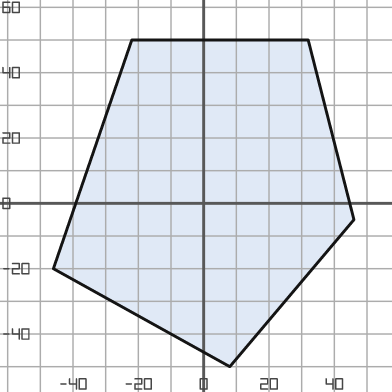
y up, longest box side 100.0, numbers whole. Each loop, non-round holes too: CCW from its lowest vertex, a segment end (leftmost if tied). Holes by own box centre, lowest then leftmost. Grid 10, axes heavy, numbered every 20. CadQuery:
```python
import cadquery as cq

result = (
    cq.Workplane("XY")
    .moveTo(8.0, -50.0)
    .lineTo(46.0, -5.0)
    .lineTo(32.0, 50.0)
    .lineTo(-22.0, 50.0)
    .lineTo(-46.0, -20.0)
    .close()
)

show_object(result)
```